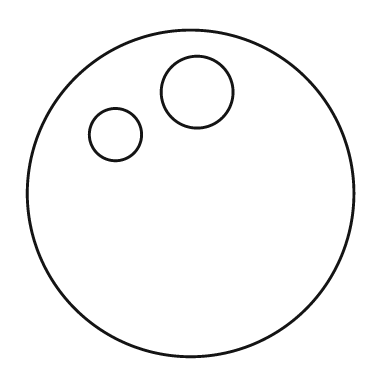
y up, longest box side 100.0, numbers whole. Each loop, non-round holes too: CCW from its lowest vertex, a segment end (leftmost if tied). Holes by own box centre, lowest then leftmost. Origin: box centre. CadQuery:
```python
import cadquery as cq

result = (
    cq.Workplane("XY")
    .moveTo(0.0, 0.0)
    .circle(50.0)
    .moveTo(-23.0, 18.0)
    .circle(8.0)
    .moveTo(2.0, 31.0)
    .circle(11.0)
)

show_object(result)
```